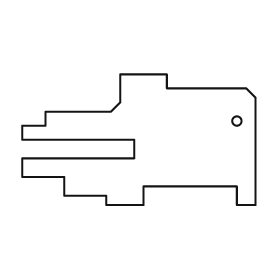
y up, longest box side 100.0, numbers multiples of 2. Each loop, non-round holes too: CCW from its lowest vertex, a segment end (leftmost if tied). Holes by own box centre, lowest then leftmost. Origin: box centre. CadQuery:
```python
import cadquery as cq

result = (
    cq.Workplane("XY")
    .moveTo(-14.0, -28.0)
    .lineTo(2.0, -28.0)
    .lineTo(2.0, -20.0)
    .lineTo(42.0, -20.0)
    .lineTo(42.0, -28.0)
    .lineTo(50.0, -28.0)
    .lineTo(50.0, 18.0)
    .lineTo(46.0, 22.0)
    .lineTo(12.0, 22.0)
    .lineTo(12.0, 28.0)
    .lineTo(-8.0, 28.0)
    .lineTo(-8.0, 16.0)
    .lineTo(-12.0, 12.0)
    .lineTo(-40.0, 12.0)
    .lineTo(-40.0, 6.0)
    .lineTo(-50.0, 6.0)
    .lineTo(-50.0, 0.0)
    .lineTo(-2.0, 0.0)
    .lineTo(-2.0, -8.0)
    .lineTo(-50.0, -8.0)
    .lineTo(-50.0, -16.0)
    .lineTo(-32.0, -16.0)
    .lineTo(-32.0, -24.0)
    .lineTo(-14.0, -24.0)
    .close()
    .moveTo(42.0, 8.0)
    .circle(2.0)
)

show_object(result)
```